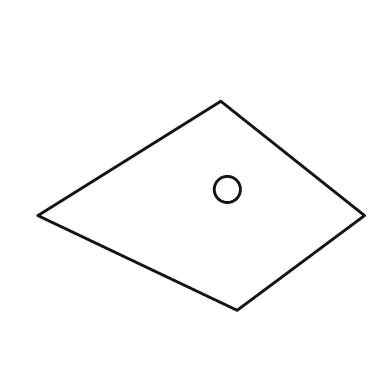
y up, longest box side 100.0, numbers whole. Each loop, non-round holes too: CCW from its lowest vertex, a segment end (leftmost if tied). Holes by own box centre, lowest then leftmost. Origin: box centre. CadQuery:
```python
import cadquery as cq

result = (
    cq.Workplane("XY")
    .moveTo(11.0, -32.0)
    .lineTo(50.0, -3.0)
    .lineTo(6.0, 32.0)
    .lineTo(-50.0, -3.0)
    .close()
    .moveTo(8.0, 5.0)
    .circle(4.0)
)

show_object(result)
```